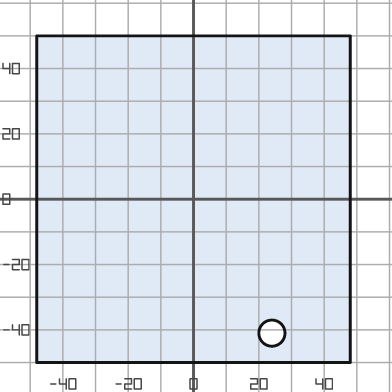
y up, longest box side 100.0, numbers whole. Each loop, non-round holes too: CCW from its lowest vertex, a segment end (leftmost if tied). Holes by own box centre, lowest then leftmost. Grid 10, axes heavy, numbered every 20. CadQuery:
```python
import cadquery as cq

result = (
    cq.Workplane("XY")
    .moveTo(-48.0, -50.0)
    .lineTo(48.0, -50.0)
    .lineTo(48.0, 50.0)
    .lineTo(-48.0, 50.0)
    .close()
    .moveTo(24.0, -41.0)
    .circle(4.0)
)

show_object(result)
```